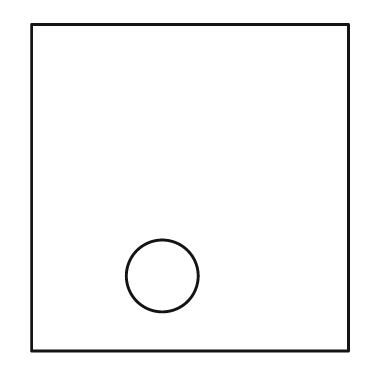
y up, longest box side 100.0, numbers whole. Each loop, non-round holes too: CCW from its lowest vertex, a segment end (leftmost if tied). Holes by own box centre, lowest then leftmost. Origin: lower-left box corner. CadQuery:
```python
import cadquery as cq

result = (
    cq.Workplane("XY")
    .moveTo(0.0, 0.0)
    .lineTo(97.0, 0.0)
    .lineTo(97.0, 100.0)
    .lineTo(0.0, 100.0)
    .close()
    .moveTo(40.0, 23.0)
    .circle(11.0)
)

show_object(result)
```